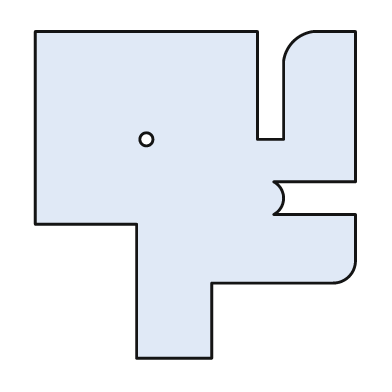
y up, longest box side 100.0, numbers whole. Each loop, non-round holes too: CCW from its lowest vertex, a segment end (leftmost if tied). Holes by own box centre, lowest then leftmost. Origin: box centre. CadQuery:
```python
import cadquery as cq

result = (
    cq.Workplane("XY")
    .moveTo(-18.0, -50.0)
    .lineTo(5.0, -50.0)
    .lineTo(5.0, -27.0)
    .lineTo(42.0, -27.0)
    .threePointArc((47.0, -25.0), (49.0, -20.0))
    .lineTo(49.0, -6.0)
    .lineTo(24.0, -6.0)
    .threePointArc((27.0, -1.0), (24.0, 4.0))
    .lineTo(49.0, 4.0)
    .lineTo(49.0, 50.0)
    .lineTo(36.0, 50.0)
    .threePointArc((30.0, 47.0), (27.0, 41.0))
    .lineTo(27.0, 17.0)
    .lineTo(19.0, 17.0)
    .lineTo(19.0, 50.0)
    .lineTo(-49.0, 50.0)
    .lineTo(-49.0, -9.0)
    .lineTo(-18.0, -9.0)
    .close()
    .moveTo(-15.0, 17.0)
    .circle(2.0)
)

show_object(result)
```